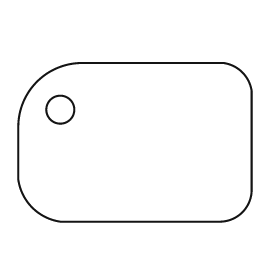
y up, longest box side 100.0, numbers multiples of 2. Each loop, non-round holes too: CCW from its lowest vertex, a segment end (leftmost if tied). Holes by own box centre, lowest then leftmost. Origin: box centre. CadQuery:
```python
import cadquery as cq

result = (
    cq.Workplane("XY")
    .moveTo(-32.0, -34.0)
    .lineTo(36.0, -34.0)
    .threePointArc((46.0, -30.0), (50.0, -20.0))
    .lineTo(50.0, 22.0)
    .threePointArc((46.0, 30.0), (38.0, 34.0))
    .lineTo(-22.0, 34.0)
    .threePointArc((-42.0, 26.0), (-50.0, 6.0))
    .lineTo(-50.0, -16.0)
    .threePointArc((-44.0, -28.0), (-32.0, -34.0))
    .close()
    .moveTo(-32.0, 14.0)
    .circle(6.0)
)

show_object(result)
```